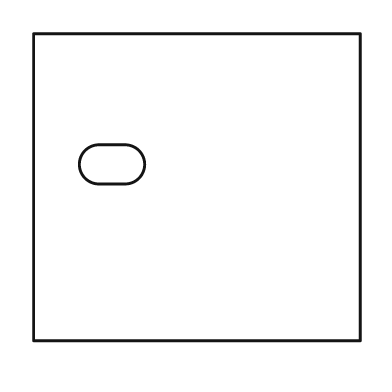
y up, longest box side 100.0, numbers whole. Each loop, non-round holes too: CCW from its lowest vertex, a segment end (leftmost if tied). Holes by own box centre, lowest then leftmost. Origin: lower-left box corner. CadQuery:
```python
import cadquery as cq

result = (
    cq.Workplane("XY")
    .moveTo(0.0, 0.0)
    .lineTo(100.0, 0.0)
    .lineTo(100.0, 94.0)
    .lineTo(0.0, 94.0)
    .close()
    .moveTo(20.0, 48.0)
    .lineTo(28.0, 48.0)
    .threePointArc((34.0, 54.0), (28.0, 60.0))
    .lineTo(20.0, 60.0)
    .threePointArc((14.0, 54.0), (20.0, 48.0))
    .close()
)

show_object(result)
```